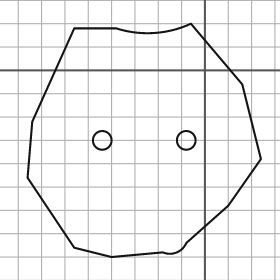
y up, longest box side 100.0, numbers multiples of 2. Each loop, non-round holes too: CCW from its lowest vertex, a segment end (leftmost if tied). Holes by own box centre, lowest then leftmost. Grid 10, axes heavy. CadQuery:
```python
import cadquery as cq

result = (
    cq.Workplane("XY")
    .moveTo(-40.0, -80.0)
    .lineTo(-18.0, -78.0)
    .threePointArc((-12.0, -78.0), (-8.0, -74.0))
    .lineTo(10.0, -58.0)
    .lineTo(24.0, -38.0)
    .lineTo(16.0, -6.0)
    .lineTo(-6.0, 20.0)
    .threePointArc((-22.0, 16.0), (-38.0, 18.0))
    .lineTo(-56.0, 18.0)
    .lineTo(-74.0, -22.0)
    .lineTo(-76.0, -46.0)
    .lineTo(-56.0, -76.0)
    .close()
    .moveTo(-44.0, -30.0)
    .circle(4.0)
    .moveTo(-8.0, -30.0)
    .circle(4.0)
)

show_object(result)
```